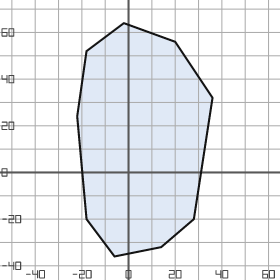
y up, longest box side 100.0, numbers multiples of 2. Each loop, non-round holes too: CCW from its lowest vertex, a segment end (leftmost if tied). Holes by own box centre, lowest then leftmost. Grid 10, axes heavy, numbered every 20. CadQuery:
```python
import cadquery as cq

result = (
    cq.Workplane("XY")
    .moveTo(-6.0, -36.0)
    .lineTo(14.0, -32.0)
    .lineTo(28.0, -20.0)
    .lineTo(36.0, 32.0)
    .lineTo(20.0, 56.0)
    .lineTo(-2.0, 64.0)
    .lineTo(-18.0, 52.0)
    .lineTo(-22.0, 24.0)
    .lineTo(-18.0, -20.0)
    .close()
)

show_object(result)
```